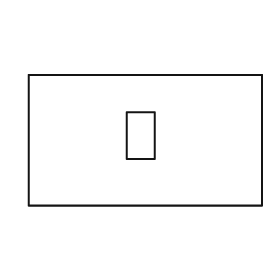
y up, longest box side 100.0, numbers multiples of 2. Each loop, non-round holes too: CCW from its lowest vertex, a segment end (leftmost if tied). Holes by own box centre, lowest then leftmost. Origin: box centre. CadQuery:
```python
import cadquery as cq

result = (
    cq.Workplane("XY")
    .moveTo(-50.0, -28.0)
    .lineTo(50.0, -28.0)
    .lineTo(50.0, 28.0)
    .lineTo(-50.0, 28.0)
    .close()
    .moveTo(-8.0, -8.0)
    .lineTo(4.0, -8.0)
    .lineTo(4.0, 12.0)
    .lineTo(-8.0, 12.0)
    .close()
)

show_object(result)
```